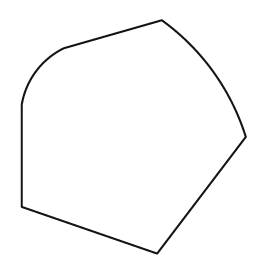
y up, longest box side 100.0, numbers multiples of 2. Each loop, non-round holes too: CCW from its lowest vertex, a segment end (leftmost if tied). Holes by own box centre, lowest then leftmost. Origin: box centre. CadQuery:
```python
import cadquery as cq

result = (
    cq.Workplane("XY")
    .moveTo(10.0, -50.0)
    .lineTo(48.0, 0.0)
    .threePointArc((34.0, 28.0), (12.0, 50.0))
    .lineTo(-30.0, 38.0)
    .threePointArc((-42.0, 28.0), (-48.0, 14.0))
    .lineTo(-48.0, -30.0)
    .close()
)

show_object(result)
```